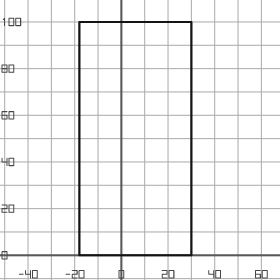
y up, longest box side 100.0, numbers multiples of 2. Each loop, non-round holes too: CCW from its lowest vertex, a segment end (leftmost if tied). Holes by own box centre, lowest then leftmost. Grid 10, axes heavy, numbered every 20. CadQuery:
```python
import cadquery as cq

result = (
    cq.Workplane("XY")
    .moveTo(-18.0, 0.0)
    .lineTo(30.0, 0.0)
    .lineTo(30.0, 100.0)
    .lineTo(-18.0, 100.0)
    .close()
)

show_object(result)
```